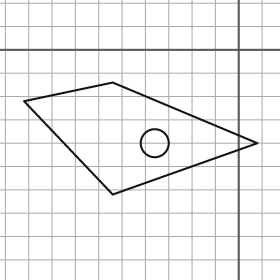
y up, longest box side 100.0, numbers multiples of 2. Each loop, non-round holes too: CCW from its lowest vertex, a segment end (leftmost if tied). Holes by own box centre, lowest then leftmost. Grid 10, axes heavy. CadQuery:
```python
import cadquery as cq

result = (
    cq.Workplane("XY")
    .moveTo(-54.0, -62.0)
    .lineTo(8.0, -40.0)
    .lineTo(-54.0, -14.0)
    .lineTo(-92.0, -22.0)
    .close()
    .moveTo(-36.0, -40.0)
    .circle(6.0)
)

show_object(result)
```